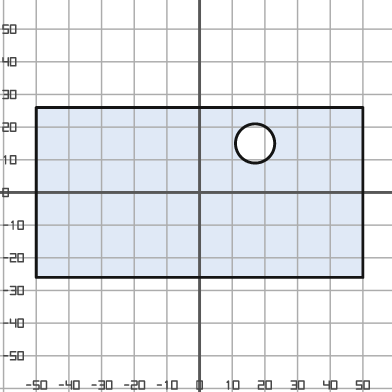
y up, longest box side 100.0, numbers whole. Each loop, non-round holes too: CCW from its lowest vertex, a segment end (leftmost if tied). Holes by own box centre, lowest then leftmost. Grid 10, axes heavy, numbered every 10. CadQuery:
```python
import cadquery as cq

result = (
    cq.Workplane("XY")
    .moveTo(-50.0, -26.0)
    .lineTo(50.0, -26.0)
    .lineTo(50.0, 26.0)
    .lineTo(-50.0, 26.0)
    .close()
    .moveTo(17.0, 15.0)
    .circle(6.0)
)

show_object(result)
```